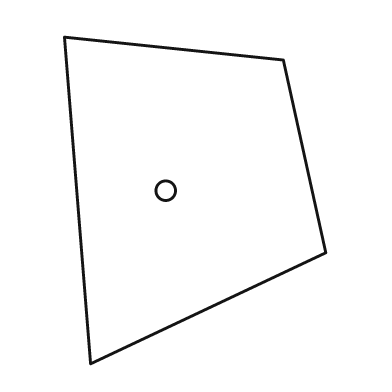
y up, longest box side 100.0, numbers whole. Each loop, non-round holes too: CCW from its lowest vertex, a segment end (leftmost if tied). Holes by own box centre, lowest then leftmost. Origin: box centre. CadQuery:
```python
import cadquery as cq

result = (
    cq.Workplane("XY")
    .moveTo(-32.0, -50.0)
    .lineTo(40.0, -16.0)
    .lineTo(27.0, 43.0)
    .lineTo(-40.0, 50.0)
    .close()
    .moveTo(-9.0, 3.0)
    .circle(3.0)
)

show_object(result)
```